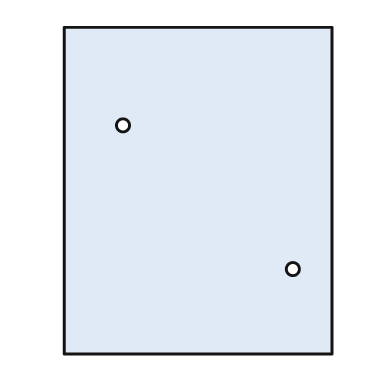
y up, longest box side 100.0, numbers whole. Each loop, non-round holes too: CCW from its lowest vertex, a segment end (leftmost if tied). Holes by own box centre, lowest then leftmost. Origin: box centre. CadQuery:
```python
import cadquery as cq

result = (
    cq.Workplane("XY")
    .moveTo(-41.0, -50.0)
    .lineTo(41.0, -50.0)
    .lineTo(41.0, 50.0)
    .lineTo(-41.0, 50.0)
    .close()
    .moveTo(29.0, -24.0)
    .circle(2.0)
    .moveTo(-23.0, 20.0)
    .circle(2.0)
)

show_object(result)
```